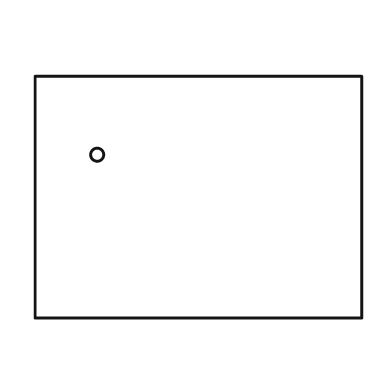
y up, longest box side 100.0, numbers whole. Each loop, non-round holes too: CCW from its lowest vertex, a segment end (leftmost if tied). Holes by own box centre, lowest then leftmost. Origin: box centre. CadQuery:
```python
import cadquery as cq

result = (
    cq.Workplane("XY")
    .moveTo(-50.0, -37.0)
    .lineTo(50.0, -37.0)
    .lineTo(50.0, 37.0)
    .lineTo(-50.0, 37.0)
    .close()
    .moveTo(-31.0, 13.0)
    .circle(2.0)
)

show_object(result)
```